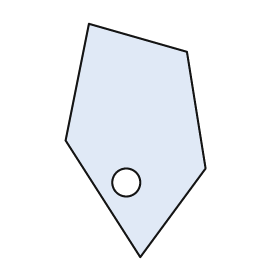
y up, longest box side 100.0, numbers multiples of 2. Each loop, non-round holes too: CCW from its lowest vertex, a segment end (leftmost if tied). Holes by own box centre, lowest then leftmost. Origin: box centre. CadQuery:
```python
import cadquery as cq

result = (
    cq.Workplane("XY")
    .moveTo(2.0, -50.0)
    .lineTo(30.0, -12.0)
    .lineTo(22.0, 38.0)
    .lineTo(-20.0, 50.0)
    .lineTo(-30.0, 0.0)
    .close()
    .moveTo(-4.0, -18.0)
    .circle(6.0)
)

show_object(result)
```